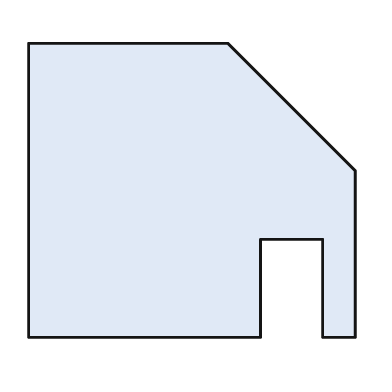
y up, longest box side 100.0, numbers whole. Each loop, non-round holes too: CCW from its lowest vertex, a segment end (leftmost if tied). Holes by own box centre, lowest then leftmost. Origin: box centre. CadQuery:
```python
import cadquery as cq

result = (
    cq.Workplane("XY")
    .moveTo(-50.0, -45.0)
    .lineTo(21.0, -45.0)
    .lineTo(21.0, -15.0)
    .lineTo(40.0, -15.0)
    .lineTo(40.0, -45.0)
    .lineTo(50.0, -45.0)
    .lineTo(50.0, 6.0)
    .lineTo(11.0, 45.0)
    .lineTo(-50.0, 45.0)
    .close()
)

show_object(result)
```